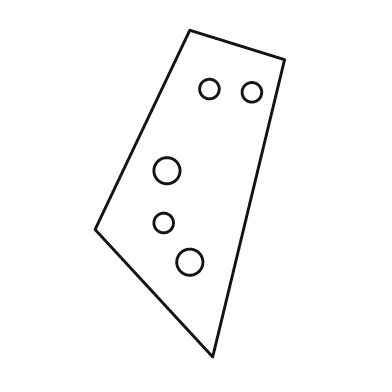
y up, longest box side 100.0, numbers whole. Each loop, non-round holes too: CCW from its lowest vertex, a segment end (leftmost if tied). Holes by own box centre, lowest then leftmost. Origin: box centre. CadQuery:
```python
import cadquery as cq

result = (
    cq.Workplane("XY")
    .moveTo(7.0, -50.0)
    .lineTo(29.0, 41.0)
    .lineTo(0.0, 50.0)
    .lineTo(-29.0, -11.0)
    .close()
    .moveTo(0.0, -21.0)
    .circle(4.0)
    .moveTo(-8.0, -9.0)
    .circle(3.0)
    .moveTo(-7.0, 7.0)
    .circle(4.0)
    .moveTo(19.0, 31.0)
    .circle(3.0)
    .moveTo(6.0, 32.0)
    .circle(3.0)
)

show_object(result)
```